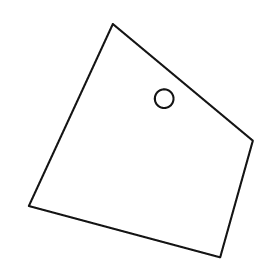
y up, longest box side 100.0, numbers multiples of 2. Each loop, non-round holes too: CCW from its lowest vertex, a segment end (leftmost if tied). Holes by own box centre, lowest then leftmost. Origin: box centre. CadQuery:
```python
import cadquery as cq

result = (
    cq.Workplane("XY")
    .moveTo(34.0, -50.0)
    .lineTo(48.0, 0.0)
    .lineTo(-12.0, 50.0)
    .lineTo(-48.0, -28.0)
    .close()
    .moveTo(10.0, 18.0)
    .circle(4.0)
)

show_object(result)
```